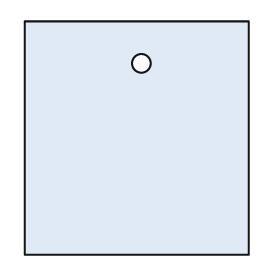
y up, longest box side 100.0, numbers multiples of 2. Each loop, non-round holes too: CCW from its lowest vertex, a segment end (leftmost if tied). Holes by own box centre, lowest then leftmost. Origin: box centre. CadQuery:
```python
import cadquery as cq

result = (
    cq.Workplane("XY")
    .moveTo(-48.0, -50.0)
    .lineTo(48.0, -50.0)
    .lineTo(48.0, 50.0)
    .lineTo(-48.0, 50.0)
    .close()
    .moveTo(2.0, 32.0)
    .circle(4.0)
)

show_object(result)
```